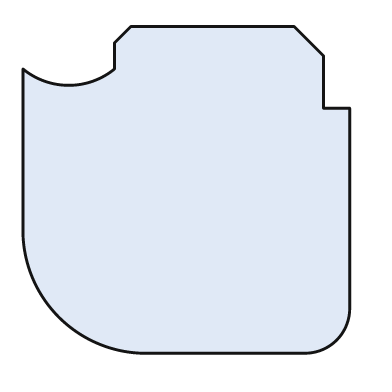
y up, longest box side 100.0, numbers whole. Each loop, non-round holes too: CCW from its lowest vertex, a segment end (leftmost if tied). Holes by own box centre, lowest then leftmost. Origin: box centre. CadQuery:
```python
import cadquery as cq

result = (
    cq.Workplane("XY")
    .moveTo(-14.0, -50.0)
    .lineTo(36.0, -50.0)
    .threePointArc((46.0, -46.0), (50.0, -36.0))
    .lineTo(50.0, 25.0)
    .lineTo(42.0, 25.0)
    .lineTo(42.0, 41.0)
    .lineTo(33.0, 50.0)
    .lineTo(-17.0, 50.0)
    .lineTo(-22.0, 45.0)
    .lineTo(-22.0, 37.0)
    .threePointArc((-36.0, 32.0), (-50.0, 37.0))
    .lineTo(-50.0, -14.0)
    .threePointArc((-39.0, -39.0), (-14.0, -50.0))
    .close()
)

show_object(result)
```